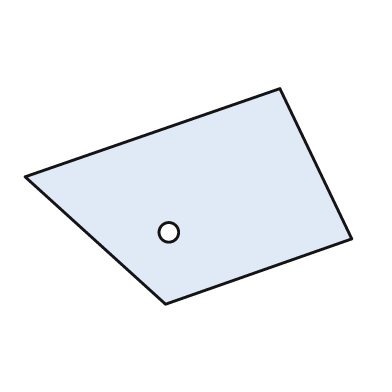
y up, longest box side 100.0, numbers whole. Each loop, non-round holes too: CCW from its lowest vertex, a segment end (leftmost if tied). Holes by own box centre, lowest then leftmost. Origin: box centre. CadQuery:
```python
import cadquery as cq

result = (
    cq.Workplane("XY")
    .moveTo(-7.0, -33.0)
    .lineTo(50.0, -13.0)
    .lineTo(28.0, 33.0)
    .lineTo(-50.0, 6.0)
    .close()
    .moveTo(-6.0, -11.0)
    .circle(3.0)
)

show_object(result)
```